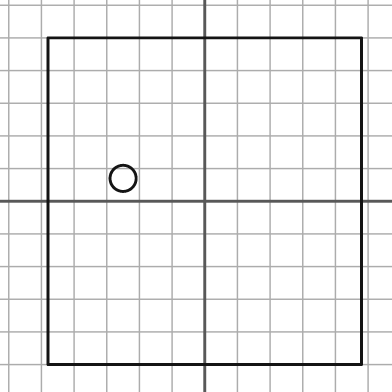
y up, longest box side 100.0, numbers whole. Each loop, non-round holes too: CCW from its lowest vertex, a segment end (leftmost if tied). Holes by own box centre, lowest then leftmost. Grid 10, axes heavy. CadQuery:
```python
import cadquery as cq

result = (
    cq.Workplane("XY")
    .moveTo(-48.0, -50.0)
    .lineTo(48.0, -50.0)
    .lineTo(48.0, 50.0)
    .lineTo(-48.0, 50.0)
    .close()
    .moveTo(-25.0, 7.0)
    .circle(4.0)
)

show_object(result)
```